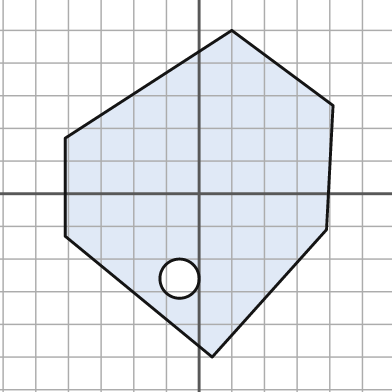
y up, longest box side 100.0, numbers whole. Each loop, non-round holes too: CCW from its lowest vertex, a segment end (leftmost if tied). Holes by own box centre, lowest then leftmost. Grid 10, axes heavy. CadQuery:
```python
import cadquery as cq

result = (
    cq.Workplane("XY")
    .moveTo(4.0, -50.0)
    .lineTo(39.0, -11.0)
    .lineTo(41.0, 27.0)
    .lineTo(10.0, 50.0)
    .lineTo(-41.0, 17.0)
    .lineTo(-41.0, -13.0)
    .close()
    .moveTo(-6.0, -26.0)
    .circle(6.0)
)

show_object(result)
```